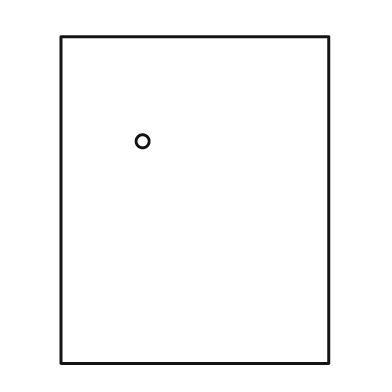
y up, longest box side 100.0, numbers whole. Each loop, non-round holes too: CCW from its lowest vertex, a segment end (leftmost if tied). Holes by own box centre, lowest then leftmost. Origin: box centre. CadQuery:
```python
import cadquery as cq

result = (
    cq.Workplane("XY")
    .moveTo(-41.0, -50.0)
    .lineTo(41.0, -50.0)
    .lineTo(41.0, 50.0)
    .lineTo(-41.0, 50.0)
    .close()
    .moveTo(-16.0, 18.0)
    .circle(2.0)
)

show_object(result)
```